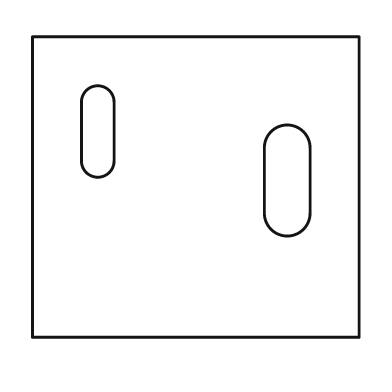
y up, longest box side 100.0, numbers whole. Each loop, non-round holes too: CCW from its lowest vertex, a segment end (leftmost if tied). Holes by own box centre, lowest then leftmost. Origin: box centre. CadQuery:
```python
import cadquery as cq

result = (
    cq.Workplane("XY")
    .moveTo(-50.0, -46.0)
    .lineTo(50.0, -46.0)
    .lineTo(50.0, 46.0)
    .lineTo(-50.0, 46.0)
    .close()
    .moveTo(21.0, -8.0)
    .threePointArc((28.0, -15.0), (35.0, -8.0))
    .lineTo(35.0, 12.0)
    .threePointArc((28.0, 19.0), (21.0, 12.0))
    .close()
    .moveTo(-35.0, 8.0)
    .threePointArc((-30.0, 3.0), (-25.0, 8.0))
    .lineTo(-25.0, 26.0)
    .threePointArc((-30.0, 31.0), (-35.0, 26.0))
    .close()
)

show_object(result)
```